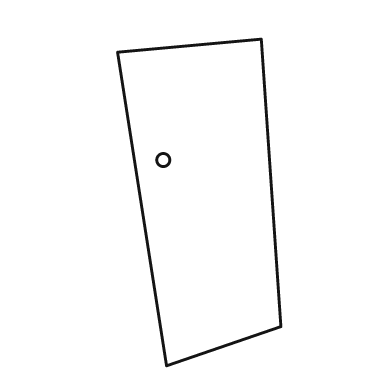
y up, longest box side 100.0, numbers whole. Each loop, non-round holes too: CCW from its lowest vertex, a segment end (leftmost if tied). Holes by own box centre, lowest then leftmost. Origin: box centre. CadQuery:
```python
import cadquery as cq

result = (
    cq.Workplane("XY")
    .moveTo(-10.0, -50.0)
    .lineTo(25.0, -38.0)
    .lineTo(19.0, 50.0)
    .lineTo(-25.0, 46.0)
    .close()
    .moveTo(-11.0, 13.0)
    .circle(2.0)
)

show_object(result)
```